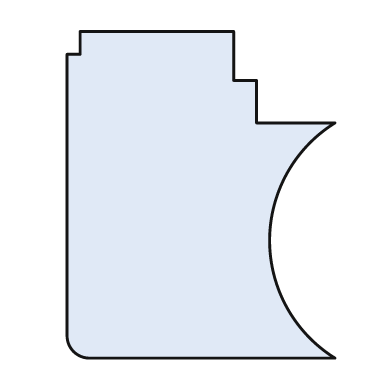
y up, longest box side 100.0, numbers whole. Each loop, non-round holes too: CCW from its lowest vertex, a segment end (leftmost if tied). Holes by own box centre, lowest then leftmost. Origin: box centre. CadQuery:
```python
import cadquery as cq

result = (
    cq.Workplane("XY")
    .moveTo(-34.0, -50.0)
    .lineTo(41.0, -50.0)
    .threePointArc((21.0, -14.0), (41.0, 22.0))
    .lineTo(17.0, 22.0)
    .lineTo(17.0, 35.0)
    .lineTo(10.0, 35.0)
    .lineTo(10.0, 50.0)
    .lineTo(-37.0, 50.0)
    .lineTo(-37.0, 43.0)
    .lineTo(-41.0, 43.0)
    .lineTo(-41.0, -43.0)
    .threePointArc((-39.0, -48.0), (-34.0, -50.0))
    .close()
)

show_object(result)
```